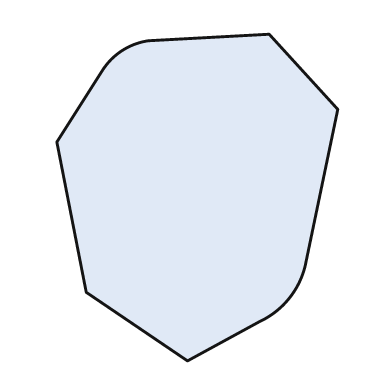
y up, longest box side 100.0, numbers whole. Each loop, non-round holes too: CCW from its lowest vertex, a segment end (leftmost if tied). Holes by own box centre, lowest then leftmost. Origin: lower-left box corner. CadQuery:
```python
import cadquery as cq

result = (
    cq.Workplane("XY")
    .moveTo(40.0, 0.0)
    .lineTo(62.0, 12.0)
    .threePointArc((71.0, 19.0), (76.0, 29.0))
    .lineTo(86.0, 77.0)
    .lineTo(65.0, 100.0)
    .lineTo(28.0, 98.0)
    .threePointArc((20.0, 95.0), (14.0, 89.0))
    .lineTo(0.0, 67.0)
    .lineTo(9.0, 21.0)
    .close()
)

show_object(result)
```